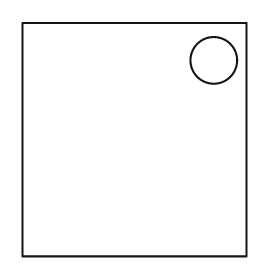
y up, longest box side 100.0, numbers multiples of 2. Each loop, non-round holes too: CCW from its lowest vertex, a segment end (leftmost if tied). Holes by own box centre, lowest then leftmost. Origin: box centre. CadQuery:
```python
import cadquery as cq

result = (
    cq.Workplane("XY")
    .moveTo(-48.0, -50.0)
    .lineTo(48.0, -50.0)
    .lineTo(48.0, 50.0)
    .lineTo(-48.0, 50.0)
    .close()
    .moveTo(34.0, 34.0)
    .circle(10.0)
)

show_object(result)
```